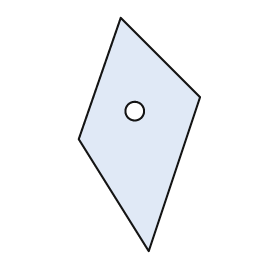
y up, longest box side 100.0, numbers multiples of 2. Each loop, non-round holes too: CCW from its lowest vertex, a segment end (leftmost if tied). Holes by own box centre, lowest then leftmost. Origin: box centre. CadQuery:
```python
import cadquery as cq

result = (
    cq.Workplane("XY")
    .moveTo(4.0, -50.0)
    .lineTo(26.0, 16.0)
    .lineTo(-8.0, 50.0)
    .lineTo(-26.0, -2.0)
    .close()
    .moveTo(-2.0, 10.0)
    .circle(4.0)
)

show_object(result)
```